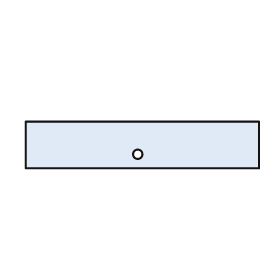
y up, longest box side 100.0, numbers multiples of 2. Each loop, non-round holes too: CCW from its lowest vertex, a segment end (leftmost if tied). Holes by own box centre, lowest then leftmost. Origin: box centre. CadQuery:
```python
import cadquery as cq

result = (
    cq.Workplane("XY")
    .moveTo(-50.0, -10.0)
    .lineTo(50.0, -10.0)
    .lineTo(50.0, 10.0)
    .lineTo(-50.0, 10.0)
    .close()
    .moveTo(-2.0, -4.0)
    .circle(2.0)
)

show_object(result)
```